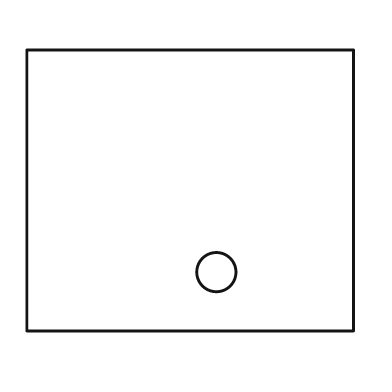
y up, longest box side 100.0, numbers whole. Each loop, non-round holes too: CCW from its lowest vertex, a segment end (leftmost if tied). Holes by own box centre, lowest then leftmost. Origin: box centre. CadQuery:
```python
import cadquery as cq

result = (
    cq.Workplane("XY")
    .moveTo(-50.0, -43.0)
    .lineTo(50.0, -43.0)
    .lineTo(50.0, 43.0)
    .lineTo(-50.0, 43.0)
    .close()
    .moveTo(8.0, -25.0)
    .circle(6.0)
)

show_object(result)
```